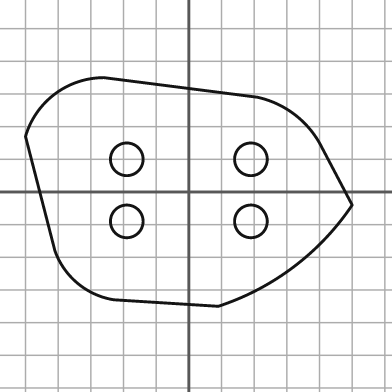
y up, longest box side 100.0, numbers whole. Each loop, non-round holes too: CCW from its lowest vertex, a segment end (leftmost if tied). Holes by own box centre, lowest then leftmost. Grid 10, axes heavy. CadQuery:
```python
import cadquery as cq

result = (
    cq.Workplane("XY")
    .moveTo(9.0, -35.0)
    .threePointArc((32.0, -23.0), (50.0, -4.0))
    .lineTo(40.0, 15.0)
    .threePointArc((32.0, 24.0), (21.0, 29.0))
    .lineTo(-26.0, 35.0)
    .threePointArc((-41.0, 30.0), (-50.0, 17.0))
    .lineTo(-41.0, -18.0)
    .threePointArc((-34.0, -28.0), (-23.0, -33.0))
    .close()
    .moveTo(-19.0, -9.0)
    .circle(5.0)
    .moveTo(19.0, -9.0)
    .circle(5.0)
    .moveTo(-19.0, 10.0)
    .circle(5.0)
    .moveTo(19.0, 10.0)
    .circle(5.0)
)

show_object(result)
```